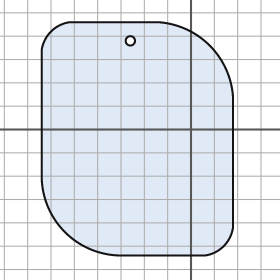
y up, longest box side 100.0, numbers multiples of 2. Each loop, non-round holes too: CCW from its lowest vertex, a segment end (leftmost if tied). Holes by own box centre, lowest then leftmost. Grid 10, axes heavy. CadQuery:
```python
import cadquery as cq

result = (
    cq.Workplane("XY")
    .moveTo(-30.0, -54.0)
    .lineTo(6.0, -54.0)
    .threePointArc((14.0, -50.0), (18.0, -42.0))
    .lineTo(18.0, 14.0)
    .threePointArc((8.0, 36.0), (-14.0, 46.0))
    .lineTo(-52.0, 46.0)
    .threePointArc((-60.0, 42.0), (-64.0, 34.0))
    .lineTo(-64.0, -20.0)
    .threePointArc((-54.0, -44.0), (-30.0, -54.0))
    .close()
    .moveTo(-26.0, 38.0)
    .circle(2.0)
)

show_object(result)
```